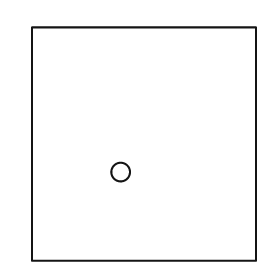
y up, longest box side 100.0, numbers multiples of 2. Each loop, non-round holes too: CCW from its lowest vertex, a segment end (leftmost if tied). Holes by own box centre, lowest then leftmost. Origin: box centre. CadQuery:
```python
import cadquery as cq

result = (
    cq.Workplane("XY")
    .moveTo(-48.0, -50.0)
    .lineTo(48.0, -50.0)
    .lineTo(48.0, 50.0)
    .lineTo(-48.0, 50.0)
    .close()
    .moveTo(-10.0, -12.0)
    .circle(4.0)
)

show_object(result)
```